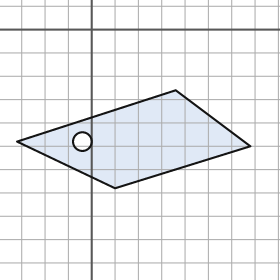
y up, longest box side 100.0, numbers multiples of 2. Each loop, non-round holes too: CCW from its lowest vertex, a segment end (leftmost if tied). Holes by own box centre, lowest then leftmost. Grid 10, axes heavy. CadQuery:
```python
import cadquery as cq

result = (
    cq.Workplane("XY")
    .moveTo(10.0, -68.0)
    .lineTo(68.0, -50.0)
    .lineTo(36.0, -26.0)
    .lineTo(-32.0, -48.0)
    .close()
    .moveTo(-4.0, -48.0)
    .circle(4.0)
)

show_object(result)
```